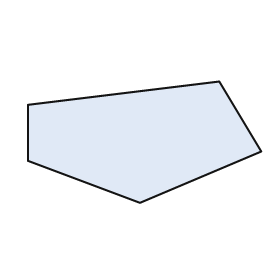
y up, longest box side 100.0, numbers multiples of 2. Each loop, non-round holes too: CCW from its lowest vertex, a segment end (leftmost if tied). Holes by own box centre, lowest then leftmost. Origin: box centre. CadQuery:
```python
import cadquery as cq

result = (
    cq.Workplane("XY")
    .moveTo(-2.0, -26.0)
    .lineTo(50.0, -4.0)
    .lineTo(32.0, 26.0)
    .lineTo(-50.0, 16.0)
    .lineTo(-50.0, -8.0)
    .close()
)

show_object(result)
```